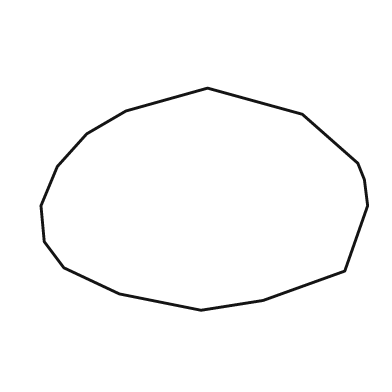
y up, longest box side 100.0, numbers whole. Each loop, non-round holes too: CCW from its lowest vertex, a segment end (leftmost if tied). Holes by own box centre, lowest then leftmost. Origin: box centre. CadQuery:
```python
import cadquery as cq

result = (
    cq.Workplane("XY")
    .moveTo(-1.0, -34.0)
    .lineTo(18.0, -31.0)
    .lineTo(43.0, -22.0)
    .lineTo(50.0, -2.0)
    .lineTo(49.0, 6.0)
    .lineTo(47.0, 11.0)
    .lineTo(30.0, 26.0)
    .lineTo(1.0, 34.0)
    .lineTo(-24.0, 27.0)
    .lineTo(-36.0, 20.0)
    .lineTo(-45.0, 10.0)
    .lineTo(-50.0, -2.0)
    .lineTo(-49.0, -13.0)
    .lineTo(-43.0, -21.0)
    .lineTo(-26.0, -29.0)
    .close()
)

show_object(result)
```